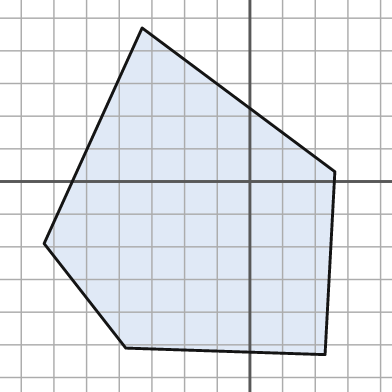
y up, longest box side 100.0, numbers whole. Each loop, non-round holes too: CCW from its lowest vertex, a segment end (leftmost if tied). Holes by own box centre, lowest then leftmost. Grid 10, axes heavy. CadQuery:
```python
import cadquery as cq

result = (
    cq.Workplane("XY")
    .moveTo(23.0, -53.0)
    .lineTo(26.0, 3.0)
    .lineTo(-33.0, 47.0)
    .lineTo(-63.0, -19.0)
    .lineTo(-38.0, -51.0)
    .close()
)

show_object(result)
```